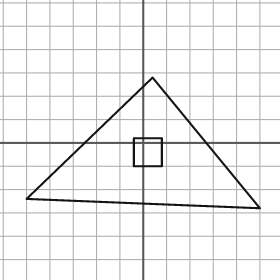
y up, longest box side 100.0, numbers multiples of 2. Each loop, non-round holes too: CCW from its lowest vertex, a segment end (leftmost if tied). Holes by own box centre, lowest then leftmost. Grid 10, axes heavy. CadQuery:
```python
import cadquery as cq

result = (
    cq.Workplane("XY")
    .moveTo(50.0, -28.0)
    .lineTo(4.0, 28.0)
    .lineTo(-50.0, -24.0)
    .close()
    .moveTo(-4.0, -10.0)
    .lineTo(8.0, -10.0)
    .lineTo(8.0, 2.0)
    .lineTo(-4.0, 2.0)
    .close()
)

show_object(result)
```